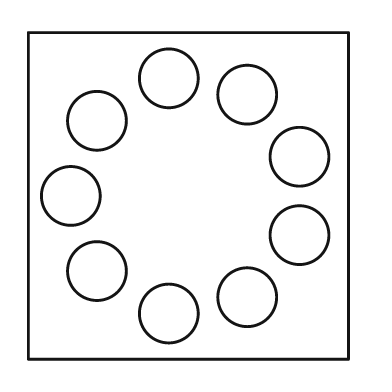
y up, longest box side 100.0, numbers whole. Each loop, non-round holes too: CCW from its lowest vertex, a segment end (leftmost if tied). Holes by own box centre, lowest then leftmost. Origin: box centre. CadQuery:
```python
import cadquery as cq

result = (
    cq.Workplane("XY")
    .moveTo(-49.0, -50.0)
    .lineTo(49.0, -50.0)
    .lineTo(49.0, 50.0)
    .lineTo(-49.0, 50.0)
    .close()
    .moveTo(-6.0, -36.0)
    .circle(9.0)
    .moveTo(18.0, -31.0)
    .circle(9.0)
    .moveTo(-28.0, -23.0)
    .circle(9.0)
    .moveTo(34.0, -12.0)
    .circle(9.0)
    .moveTo(-36.0, 0.0)
    .circle(9.0)
    .moveTo(34.0, 12.0)
    .circle(9.0)
    .moveTo(-28.0, 23.0)
    .circle(9.0)
    .moveTo(18.0, 31.0)
    .circle(9.0)
    .moveTo(-6.0, 36.0)
    .circle(9.0)
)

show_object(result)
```